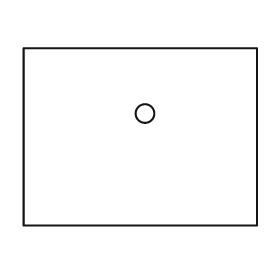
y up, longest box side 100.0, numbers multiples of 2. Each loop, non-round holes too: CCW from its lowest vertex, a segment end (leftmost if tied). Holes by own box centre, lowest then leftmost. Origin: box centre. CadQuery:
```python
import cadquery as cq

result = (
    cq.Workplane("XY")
    .moveTo(-50.0, -38.0)
    .lineTo(50.0, -38.0)
    .lineTo(50.0, 38.0)
    .lineTo(-50.0, 38.0)
    .close()
    .moveTo(2.0, 10.0)
    .circle(4.0)
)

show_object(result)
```